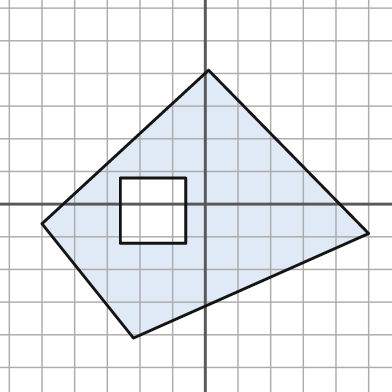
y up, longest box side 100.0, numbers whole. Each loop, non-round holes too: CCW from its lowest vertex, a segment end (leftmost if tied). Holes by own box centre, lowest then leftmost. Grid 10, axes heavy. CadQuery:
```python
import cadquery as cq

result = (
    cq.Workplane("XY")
    .moveTo(-22.0, -41.0)
    .lineTo(50.0, -9.0)
    .lineTo(1.0, 41.0)
    .lineTo(-50.0, -6.0)
    .close()
    .moveTo(-26.0, -12.0)
    .lineTo(-6.0, -12.0)
    .lineTo(-6.0, 8.0)
    .lineTo(-26.0, 8.0)
    .close()
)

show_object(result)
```